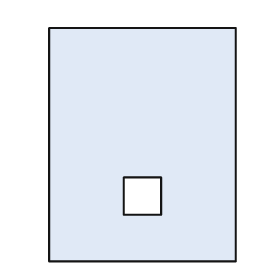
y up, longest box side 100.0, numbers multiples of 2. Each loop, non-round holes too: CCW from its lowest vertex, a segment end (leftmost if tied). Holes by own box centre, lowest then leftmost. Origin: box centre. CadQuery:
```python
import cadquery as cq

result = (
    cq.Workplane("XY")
    .moveTo(-40.0, -50.0)
    .lineTo(40.0, -50.0)
    .lineTo(40.0, 50.0)
    .lineTo(-40.0, 50.0)
    .close()
    .moveTo(-8.0, -30.0)
    .lineTo(8.0, -30.0)
    .lineTo(8.0, -14.0)
    .lineTo(-8.0, -14.0)
    .close()
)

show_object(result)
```